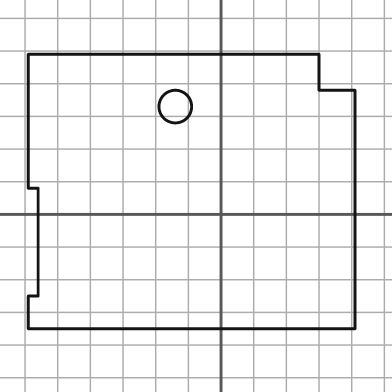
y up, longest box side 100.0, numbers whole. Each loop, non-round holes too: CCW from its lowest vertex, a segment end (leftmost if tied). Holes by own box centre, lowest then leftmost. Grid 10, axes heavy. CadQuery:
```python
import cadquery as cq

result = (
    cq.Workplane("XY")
    .moveTo(-59.0, -35.0)
    .lineTo(41.0, -35.0)
    .lineTo(41.0, 38.0)
    .lineTo(30.0, 38.0)
    .lineTo(30.0, 49.0)
    .lineTo(-59.0, 49.0)
    .lineTo(-59.0, 8.0)
    .lineTo(-56.0, 8.0)
    .lineTo(-56.0, -25.0)
    .lineTo(-59.0, -25.0)
    .close()
    .moveTo(-14.0, 33.0)
    .circle(5.0)
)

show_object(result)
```